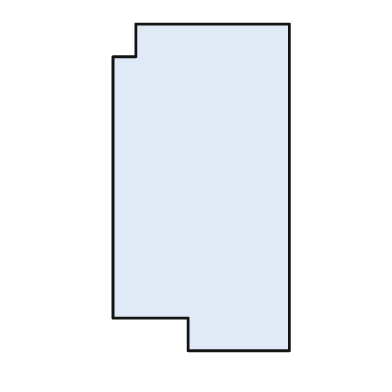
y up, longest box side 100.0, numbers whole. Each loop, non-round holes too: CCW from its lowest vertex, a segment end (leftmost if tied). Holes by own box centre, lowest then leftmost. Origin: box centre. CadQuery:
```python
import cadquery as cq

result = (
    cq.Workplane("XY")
    .moveTo(-4.0, -50.0)
    .lineTo(27.0, -50.0)
    .lineTo(27.0, 50.0)
    .lineTo(-20.0, 50.0)
    .lineTo(-20.0, 40.0)
    .lineTo(-27.0, 40.0)
    .lineTo(-27.0, -40.0)
    .lineTo(-4.0, -40.0)
    .close()
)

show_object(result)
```